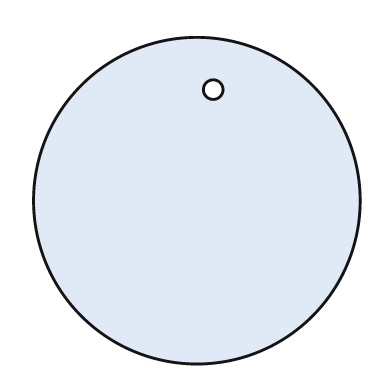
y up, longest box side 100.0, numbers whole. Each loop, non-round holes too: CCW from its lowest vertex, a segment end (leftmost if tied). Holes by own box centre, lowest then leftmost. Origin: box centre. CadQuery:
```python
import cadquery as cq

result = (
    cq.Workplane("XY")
    .moveTo(0.0, 0.0)
    .circle(50.0)
    .moveTo(5.0, 34.0)
    .circle(3.0)
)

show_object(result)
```